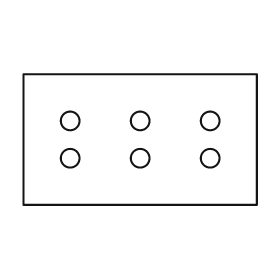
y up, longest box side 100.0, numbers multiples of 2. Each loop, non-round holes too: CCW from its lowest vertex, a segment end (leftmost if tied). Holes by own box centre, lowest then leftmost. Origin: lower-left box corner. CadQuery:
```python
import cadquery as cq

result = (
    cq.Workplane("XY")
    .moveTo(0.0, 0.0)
    .lineTo(100.0, 0.0)
    .lineTo(100.0, 56.0)
    .lineTo(0.0, 56.0)
    .close()
    .moveTo(20.0, 20.0)
    .circle(4.0)
    .moveTo(50.0, 20.0)
    .circle(4.0)
    .moveTo(80.0, 20.0)
    .circle(4.0)
    .moveTo(20.0, 36.0)
    .circle(4.0)
    .moveTo(50.0, 36.0)
    .circle(4.0)
    .moveTo(80.0, 36.0)
    .circle(4.0)
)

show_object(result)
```